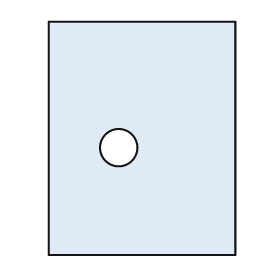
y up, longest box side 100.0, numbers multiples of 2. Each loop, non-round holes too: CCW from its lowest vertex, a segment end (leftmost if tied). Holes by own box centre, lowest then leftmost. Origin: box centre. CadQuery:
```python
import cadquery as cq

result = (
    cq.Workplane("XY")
    .moveTo(-40.0, -50.0)
    .lineTo(40.0, -50.0)
    .lineTo(40.0, 50.0)
    .lineTo(-40.0, 50.0)
    .close()
    .moveTo(-10.0, -4.0)
    .circle(8.0)
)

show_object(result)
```